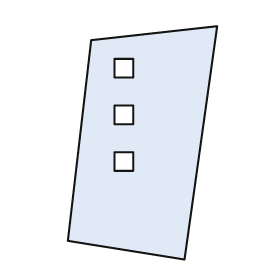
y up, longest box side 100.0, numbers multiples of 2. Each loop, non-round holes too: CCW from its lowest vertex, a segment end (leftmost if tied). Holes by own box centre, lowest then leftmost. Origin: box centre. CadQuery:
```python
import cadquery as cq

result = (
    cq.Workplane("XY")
    .moveTo(18.0, -50.0)
    .lineTo(32.0, 50.0)
    .lineTo(-22.0, 44.0)
    .lineTo(-32.0, -42.0)
    .close()
    .moveTo(-12.0, -12.0)
    .lineTo(-4.0, -12.0)
    .lineTo(-4.0, -4.0)
    .lineTo(-12.0, -4.0)
    .close()
    .moveTo(-12.0, 8.0)
    .lineTo(-4.0, 8.0)
    .lineTo(-4.0, 16.0)
    .lineTo(-12.0, 16.0)
    .close()
    .moveTo(-12.0, 28.0)
    .lineTo(-4.0, 28.0)
    .lineTo(-4.0, 36.0)
    .lineTo(-12.0, 36.0)
    .close()
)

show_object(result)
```